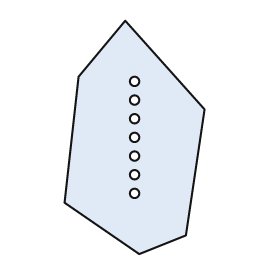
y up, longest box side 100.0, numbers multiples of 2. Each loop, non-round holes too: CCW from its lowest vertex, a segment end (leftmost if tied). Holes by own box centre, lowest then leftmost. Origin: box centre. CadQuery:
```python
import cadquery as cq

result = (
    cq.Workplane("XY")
    .moveTo(2.0, -50.0)
    .lineTo(22.0, -42.0)
    .lineTo(30.0, 12.0)
    .lineTo(-4.0, 50.0)
    .lineTo(-24.0, 26.0)
    .lineTo(-30.0, -28.0)
    .close()
    .moveTo(0.0, -24.0)
    .circle(2.0)
    .moveTo(0.0, -16.0)
    .circle(2.0)
    .moveTo(0.0, -8.0)
    .circle(2.0)
    .moveTo(0.0, 0.0)
    .circle(2.0)
    .moveTo(0.0, 8.0)
    .circle(2.0)
    .moveTo(0.0, 16.0)
    .circle(2.0)
    .moveTo(0.0, 24.0)
    .circle(2.0)
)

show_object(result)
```